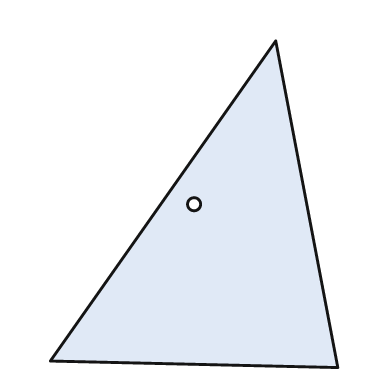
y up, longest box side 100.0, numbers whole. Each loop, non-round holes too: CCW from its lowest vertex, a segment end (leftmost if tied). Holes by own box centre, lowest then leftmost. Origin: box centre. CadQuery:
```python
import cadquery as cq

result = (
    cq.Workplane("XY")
    .moveTo(44.0, -50.0)
    .lineTo(25.0, 50.0)
    .lineTo(-44.0, -48.0)
    .close()
    .moveTo(0.0, 0.0)
    .circle(2.0)
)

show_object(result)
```